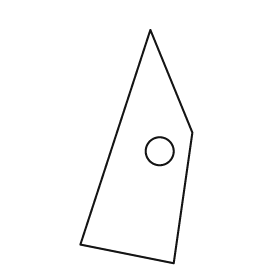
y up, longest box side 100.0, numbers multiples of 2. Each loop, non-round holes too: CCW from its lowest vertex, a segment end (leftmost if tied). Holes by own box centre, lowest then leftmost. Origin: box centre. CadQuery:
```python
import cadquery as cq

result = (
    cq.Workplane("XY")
    .moveTo(16.0, -50.0)
    .lineTo(24.0, 6.0)
    .lineTo(6.0, 50.0)
    .lineTo(-24.0, -42.0)
    .close()
    .moveTo(10.0, -2.0)
    .circle(6.0)
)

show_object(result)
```